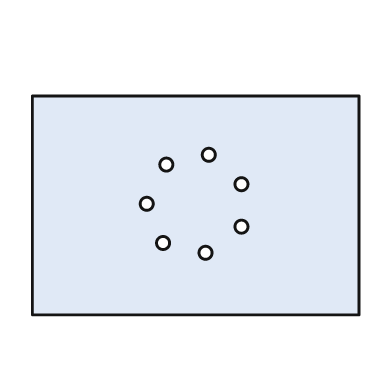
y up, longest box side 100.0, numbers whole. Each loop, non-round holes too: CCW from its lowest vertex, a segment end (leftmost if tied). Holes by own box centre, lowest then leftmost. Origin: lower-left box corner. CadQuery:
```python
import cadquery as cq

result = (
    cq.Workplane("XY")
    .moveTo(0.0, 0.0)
    .lineTo(100.0, 0.0)
    .lineTo(100.0, 67.0)
    .lineTo(0.0, 67.0)
    .close()
    .moveTo(53.0, 19.0)
    .circle(2.0)
    .moveTo(40.0, 22.0)
    .circle(2.0)
    .moveTo(64.0, 27.0)
    .circle(2.0)
    .moveTo(35.0, 34.0)
    .circle(2.0)
    .moveTo(64.0, 40.0)
    .circle(2.0)
    .moveTo(41.0, 46.0)
    .circle(2.0)
    .moveTo(54.0, 49.0)
    .circle(2.0)
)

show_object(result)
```